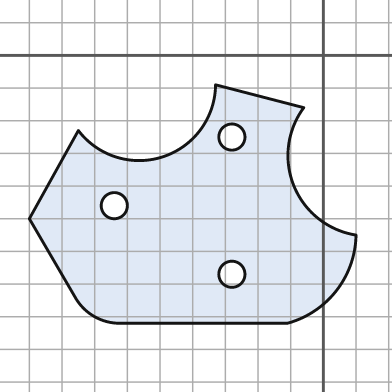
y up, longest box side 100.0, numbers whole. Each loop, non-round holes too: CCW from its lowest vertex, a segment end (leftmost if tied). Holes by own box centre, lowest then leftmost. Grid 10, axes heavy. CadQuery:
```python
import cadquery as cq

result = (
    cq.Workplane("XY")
    .moveTo(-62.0, -82.0)
    .lineTo(-11.0, -82.0)
    .threePointArc((4.0, -72.0), (10.0, -55.0))
    .threePointArc((-9.0, -40.0), (-6.0, -16.0))
    .lineTo(-33.0, -9.0)
    .threePointArc((-49.0, -31.0), (-75.0, -23.0))
    .lineTo(-90.0, -50.0)
    .lineTo(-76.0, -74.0)
    .threePointArc((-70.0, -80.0), (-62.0, -82.0))
    .close()
    .moveTo(-28.0, -67.0)
    .circle(4.0)
    .moveTo(-64.0, -46.0)
    .circle(4.0)
    .moveTo(-28.0, -25.0)
    .circle(4.0)
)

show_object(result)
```